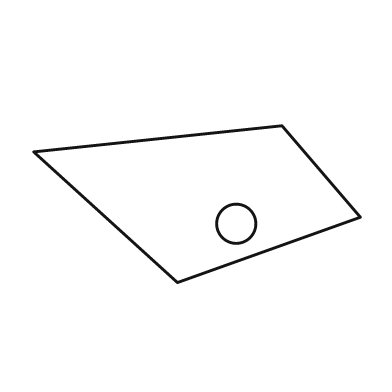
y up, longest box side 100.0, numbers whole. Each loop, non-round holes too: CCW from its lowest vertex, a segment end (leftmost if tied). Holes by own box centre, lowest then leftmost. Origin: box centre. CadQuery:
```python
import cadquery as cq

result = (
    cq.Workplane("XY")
    .moveTo(-6.0, -24.0)
    .lineTo(50.0, -4.0)
    .lineTo(26.0, 24.0)
    .lineTo(-50.0, 16.0)
    .close()
    .moveTo(12.0, -6.0)
    .circle(6.0)
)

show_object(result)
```